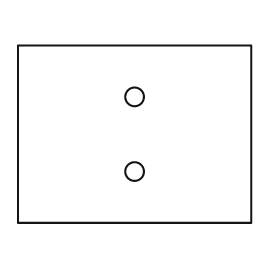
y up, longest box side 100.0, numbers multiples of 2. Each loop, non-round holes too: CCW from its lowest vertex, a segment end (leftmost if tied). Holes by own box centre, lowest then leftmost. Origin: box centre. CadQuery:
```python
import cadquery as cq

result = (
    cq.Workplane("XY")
    .moveTo(-50.0, -38.0)
    .lineTo(50.0, -38.0)
    .lineTo(50.0, 38.0)
    .lineTo(-50.0, 38.0)
    .close()
    .moveTo(0.0, -16.0)
    .circle(4.0)
    .moveTo(0.0, 16.0)
    .circle(4.0)
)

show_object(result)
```